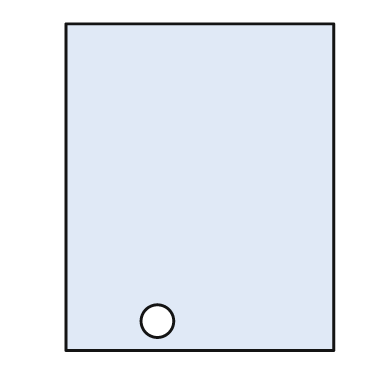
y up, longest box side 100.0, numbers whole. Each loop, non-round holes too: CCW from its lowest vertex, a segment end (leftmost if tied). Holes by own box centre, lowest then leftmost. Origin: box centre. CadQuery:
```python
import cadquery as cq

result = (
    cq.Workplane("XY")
    .moveTo(-41.0, -50.0)
    .lineTo(41.0, -50.0)
    .lineTo(41.0, 50.0)
    .lineTo(-41.0, 50.0)
    .close()
    .moveTo(-13.0, -41.0)
    .circle(5.0)
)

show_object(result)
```